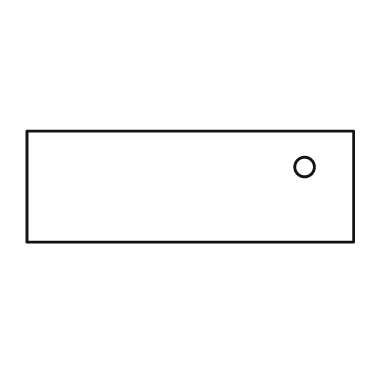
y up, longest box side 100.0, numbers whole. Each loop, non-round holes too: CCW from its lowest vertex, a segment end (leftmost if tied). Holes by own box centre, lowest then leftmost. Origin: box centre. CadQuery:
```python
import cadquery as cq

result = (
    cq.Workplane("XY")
    .moveTo(-50.0, -17.0)
    .lineTo(50.0, -17.0)
    .lineTo(50.0, 17.0)
    .lineTo(-50.0, 17.0)
    .close()
    .moveTo(35.0, 6.0)
    .circle(3.0)
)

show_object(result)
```